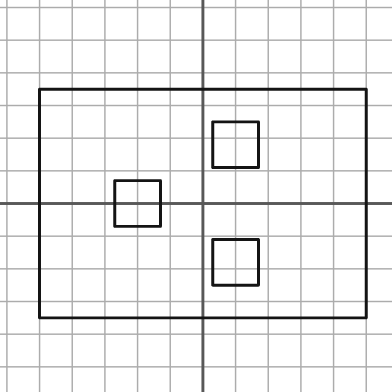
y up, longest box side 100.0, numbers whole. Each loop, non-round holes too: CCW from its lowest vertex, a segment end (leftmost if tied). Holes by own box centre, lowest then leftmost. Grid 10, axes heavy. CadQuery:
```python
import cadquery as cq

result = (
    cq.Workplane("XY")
    .moveTo(-50.0, -35.0)
    .lineTo(50.0, -35.0)
    .lineTo(50.0, 35.0)
    .lineTo(-50.0, 35.0)
    .close()
    .moveTo(3.0, -25.0)
    .lineTo(17.0, -25.0)
    .lineTo(17.0, -11.0)
    .lineTo(3.0, -11.0)
    .close()
    .moveTo(-27.0, -7.0)
    .lineTo(-13.0, -7.0)
    .lineTo(-13.0, 7.0)
    .lineTo(-27.0, 7.0)
    .close()
    .moveTo(3.0, 11.0)
    .lineTo(17.0, 11.0)
    .lineTo(17.0, 25.0)
    .lineTo(3.0, 25.0)
    .close()
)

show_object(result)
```